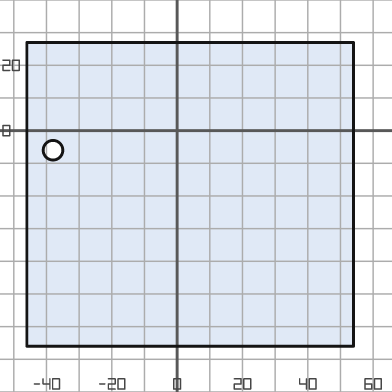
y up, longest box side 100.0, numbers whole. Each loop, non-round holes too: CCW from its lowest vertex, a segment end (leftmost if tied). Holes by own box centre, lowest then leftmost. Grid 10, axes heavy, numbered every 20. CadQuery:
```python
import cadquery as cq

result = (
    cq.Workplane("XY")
    .moveTo(-46.0, -66.0)
    .lineTo(54.0, -66.0)
    .lineTo(54.0, 27.0)
    .lineTo(-46.0, 27.0)
    .close()
    .moveTo(-38.0, -6.0)
    .circle(3.0)
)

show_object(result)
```